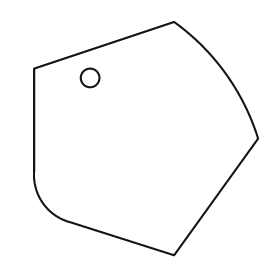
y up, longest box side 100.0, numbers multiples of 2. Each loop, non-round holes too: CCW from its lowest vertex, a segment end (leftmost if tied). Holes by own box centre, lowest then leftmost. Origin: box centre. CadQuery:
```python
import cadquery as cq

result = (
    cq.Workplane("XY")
    .moveTo(12.0, -50.0)
    .lineTo(48.0, 0.0)
    .threePointArc((34.0, 28.0), (12.0, 50.0))
    .lineTo(-48.0, 30.0)
    .lineTo(-48.0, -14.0)
    .threePointArc((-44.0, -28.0), (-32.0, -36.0))
    .close()
    .moveTo(-24.0, 26.0)
    .circle(4.0)
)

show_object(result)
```